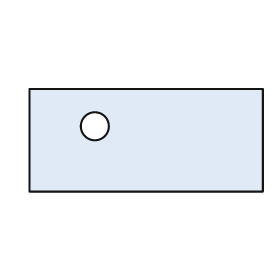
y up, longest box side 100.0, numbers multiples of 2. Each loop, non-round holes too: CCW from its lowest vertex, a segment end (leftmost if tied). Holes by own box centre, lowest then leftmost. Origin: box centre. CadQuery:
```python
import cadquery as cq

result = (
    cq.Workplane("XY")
    .moveTo(-50.0, -22.0)
    .lineTo(50.0, -22.0)
    .lineTo(50.0, 22.0)
    .lineTo(-50.0, 22.0)
    .close()
    .moveTo(-22.0, 6.0)
    .circle(6.0)
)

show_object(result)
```